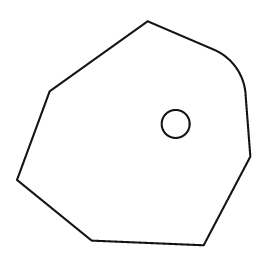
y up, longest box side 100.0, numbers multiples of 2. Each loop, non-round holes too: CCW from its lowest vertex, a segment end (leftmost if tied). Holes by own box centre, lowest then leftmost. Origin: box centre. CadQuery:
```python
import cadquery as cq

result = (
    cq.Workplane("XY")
    .moveTo(30.0, -48.0)
    .lineTo(50.0, -10.0)
    .lineTo(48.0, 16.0)
    .threePointArc((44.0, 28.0), (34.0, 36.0))
    .lineTo(6.0, 48.0)
    .lineTo(-36.0, 18.0)
    .lineTo(-50.0, -20.0)
    .lineTo(-18.0, -46.0)
    .close()
    .moveTo(18.0, 4.0)
    .circle(6.0)
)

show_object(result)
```